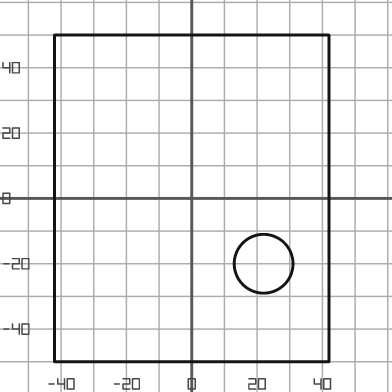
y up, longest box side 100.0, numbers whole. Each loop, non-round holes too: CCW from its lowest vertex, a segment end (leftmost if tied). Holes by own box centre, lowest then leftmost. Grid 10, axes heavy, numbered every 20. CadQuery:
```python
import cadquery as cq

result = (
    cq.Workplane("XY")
    .moveTo(-42.0, -50.0)
    .lineTo(42.0, -50.0)
    .lineTo(42.0, 50.0)
    .lineTo(-42.0, 50.0)
    .close()
    .moveTo(22.0, -20.0)
    .circle(9.0)
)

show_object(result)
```